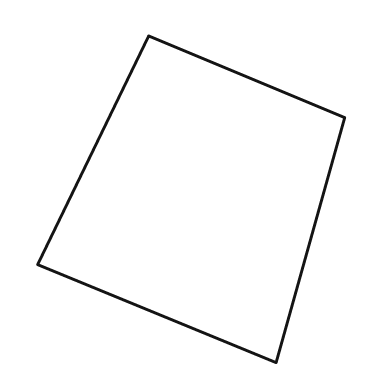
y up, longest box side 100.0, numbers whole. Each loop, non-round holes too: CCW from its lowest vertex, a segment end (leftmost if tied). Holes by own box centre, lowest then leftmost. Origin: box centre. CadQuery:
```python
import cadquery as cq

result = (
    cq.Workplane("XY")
    .moveTo(26.0, -50.0)
    .lineTo(47.0, 25.0)
    .lineTo(-13.0, 50.0)
    .lineTo(-47.0, -20.0)
    .close()
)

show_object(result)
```